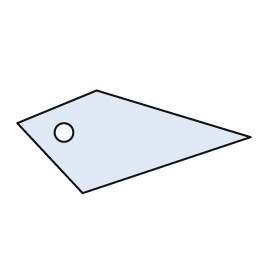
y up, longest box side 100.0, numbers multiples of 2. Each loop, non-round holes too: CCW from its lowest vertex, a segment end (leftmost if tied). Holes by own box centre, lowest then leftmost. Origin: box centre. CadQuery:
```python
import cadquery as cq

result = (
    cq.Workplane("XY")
    .moveTo(-22.0, -22.0)
    .lineTo(50.0, 2.0)
    .lineTo(-16.0, 22.0)
    .lineTo(-50.0, 8.0)
    .close()
    .moveTo(-30.0, 4.0)
    .circle(4.0)
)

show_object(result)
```